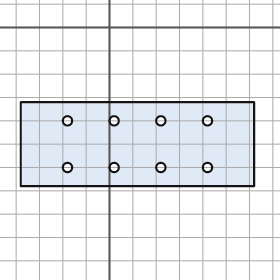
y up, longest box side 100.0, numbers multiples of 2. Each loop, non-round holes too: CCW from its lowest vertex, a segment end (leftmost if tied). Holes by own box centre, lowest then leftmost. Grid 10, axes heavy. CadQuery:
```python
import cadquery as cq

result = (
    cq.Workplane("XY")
    .moveTo(-38.0, -68.0)
    .lineTo(62.0, -68.0)
    .lineTo(62.0, -32.0)
    .lineTo(-38.0, -32.0)
    .close()
    .moveTo(-18.0, -60.0)
    .circle(2.0)
    .moveTo(2.0, -60.0)
    .circle(2.0)
    .moveTo(22.0, -60.0)
    .circle(2.0)
    .moveTo(42.0, -60.0)
    .circle(2.0)
    .moveTo(-18.0, -40.0)
    .circle(2.0)
    .moveTo(2.0, -40.0)
    .circle(2.0)
    .moveTo(22.0, -40.0)
    .circle(2.0)
    .moveTo(42.0, -40.0)
    .circle(2.0)
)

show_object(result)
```